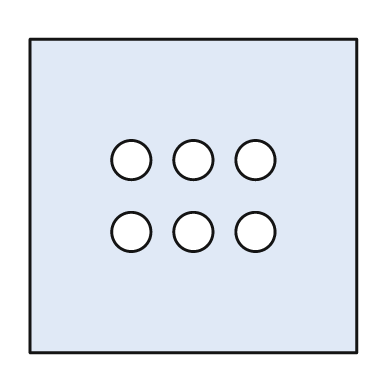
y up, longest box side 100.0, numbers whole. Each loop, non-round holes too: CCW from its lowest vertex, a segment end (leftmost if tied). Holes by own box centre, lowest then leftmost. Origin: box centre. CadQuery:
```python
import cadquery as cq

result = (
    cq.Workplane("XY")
    .moveTo(-50.0, -48.0)
    .lineTo(50.0, -48.0)
    .lineTo(50.0, 48.0)
    .lineTo(-50.0, 48.0)
    .close()
    .moveTo(-19.0, -11.0)
    .circle(6.0)
    .moveTo(0.0, -11.0)
    .circle(6.0)
    .moveTo(19.0, -11.0)
    .circle(6.0)
    .moveTo(-19.0, 11.0)
    .circle(6.0)
    .moveTo(0.0, 11.0)
    .circle(6.0)
    .moveTo(19.0, 11.0)
    .circle(6.0)
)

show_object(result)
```